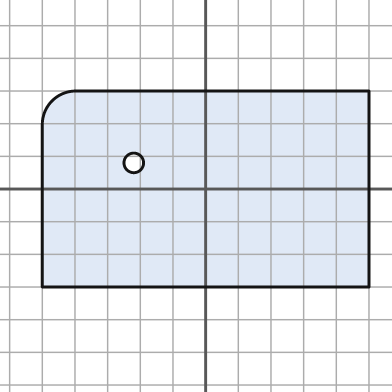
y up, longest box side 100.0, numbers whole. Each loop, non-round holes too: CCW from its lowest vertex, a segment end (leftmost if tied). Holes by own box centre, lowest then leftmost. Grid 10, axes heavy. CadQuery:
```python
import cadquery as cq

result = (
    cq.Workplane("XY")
    .moveTo(-50.0, -30.0)
    .lineTo(50.0, -30.0)
    .lineTo(50.0, 30.0)
    .lineTo(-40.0, 30.0)
    .threePointArc((-47.0, 27.0), (-50.0, 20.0))
    .close()
    .moveTo(-22.0, 8.0)
    .circle(3.0)
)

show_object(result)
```